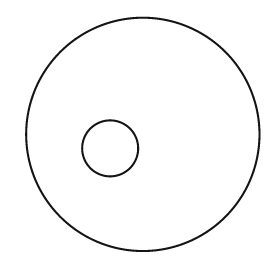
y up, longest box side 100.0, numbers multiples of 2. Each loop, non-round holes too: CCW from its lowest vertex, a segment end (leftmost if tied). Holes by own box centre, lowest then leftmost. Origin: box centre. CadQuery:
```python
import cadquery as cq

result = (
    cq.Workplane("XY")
    .moveTo(0.0, 0.0)
    .circle(50.0)
    .moveTo(-14.0, -6.0)
    .circle(12.0)
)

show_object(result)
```